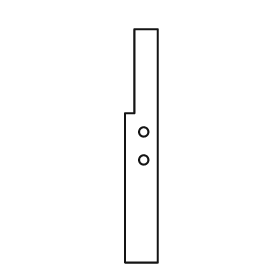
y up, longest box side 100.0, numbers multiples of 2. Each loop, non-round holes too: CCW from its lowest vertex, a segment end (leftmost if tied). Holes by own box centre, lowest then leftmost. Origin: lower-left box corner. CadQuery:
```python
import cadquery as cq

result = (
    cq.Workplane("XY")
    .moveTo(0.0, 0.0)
    .lineTo(14.0, 0.0)
    .lineTo(14.0, 100.0)
    .lineTo(4.0, 100.0)
    .lineTo(4.0, 64.0)
    .lineTo(0.0, 64.0)
    .close()
    .moveTo(8.0, 44.0)
    .circle(2.0)
    .moveTo(8.0, 56.0)
    .circle(2.0)
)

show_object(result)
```